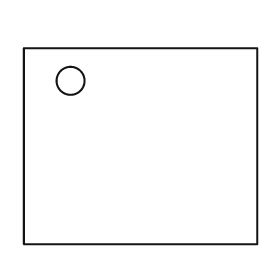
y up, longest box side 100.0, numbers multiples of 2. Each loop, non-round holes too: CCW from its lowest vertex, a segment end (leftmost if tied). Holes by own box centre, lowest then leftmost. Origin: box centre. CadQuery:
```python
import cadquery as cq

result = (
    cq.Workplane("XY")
    .moveTo(-50.0, -42.0)
    .lineTo(50.0, -42.0)
    .lineTo(50.0, 42.0)
    .lineTo(-50.0, 42.0)
    .close()
    .moveTo(-30.0, 28.0)
    .circle(6.0)
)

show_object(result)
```